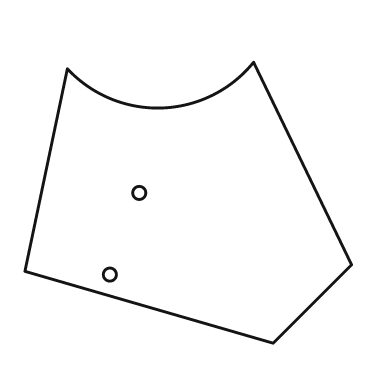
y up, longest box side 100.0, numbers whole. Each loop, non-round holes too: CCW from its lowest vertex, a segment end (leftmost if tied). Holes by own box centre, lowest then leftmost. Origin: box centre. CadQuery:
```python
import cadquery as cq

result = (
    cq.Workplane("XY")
    .moveTo(26.0, -43.0)
    .lineTo(50.0, -19.0)
    .lineTo(20.0, 43.0)
    .threePointArc((-8.0, 29.0), (-37.0, 41.0))
    .lineTo(-50.0, -21.0)
    .close()
    .moveTo(-24.0, -22.0)
    .circle(2.0)
    .moveTo(-15.0, 3.0)
    .circle(2.0)
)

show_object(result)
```